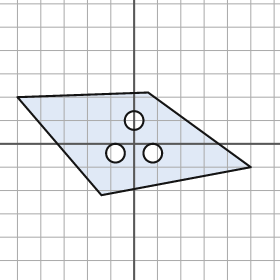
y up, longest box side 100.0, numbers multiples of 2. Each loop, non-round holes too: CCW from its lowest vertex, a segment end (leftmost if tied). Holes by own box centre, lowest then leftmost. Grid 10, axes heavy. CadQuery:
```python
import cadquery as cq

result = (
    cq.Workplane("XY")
    .moveTo(-14.0, -22.0)
    .lineTo(50.0, -10.0)
    .lineTo(6.0, 22.0)
    .lineTo(-50.0, 20.0)
    .close()
    .moveTo(-8.0, -4.0)
    .circle(4.0)
    .moveTo(8.0, -4.0)
    .circle(4.0)
    .moveTo(0.0, 10.0)
    .circle(4.0)
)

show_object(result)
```